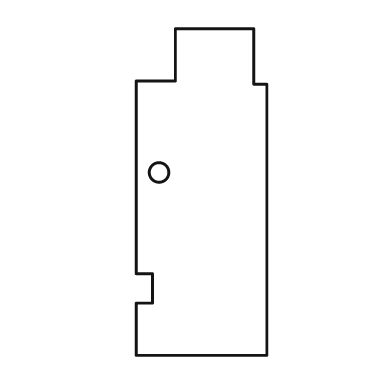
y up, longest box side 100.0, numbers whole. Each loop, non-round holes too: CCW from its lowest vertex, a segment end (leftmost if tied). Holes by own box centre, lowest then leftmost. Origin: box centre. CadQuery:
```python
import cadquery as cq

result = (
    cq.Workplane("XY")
    .moveTo(-20.0, -50.0)
    .lineTo(20.0, -50.0)
    .lineTo(20.0, 33.0)
    .lineTo(16.0, 33.0)
    .lineTo(16.0, 50.0)
    .lineTo(-8.0, 50.0)
    .lineTo(-8.0, 34.0)
    .lineTo(-20.0, 34.0)
    .lineTo(-20.0, -25.0)
    .lineTo(-15.0, -25.0)
    .lineTo(-15.0, -34.0)
    .lineTo(-20.0, -34.0)
    .close()
    .moveTo(-13.0, 6.0)
    .circle(3.0)
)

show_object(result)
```